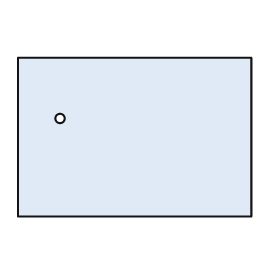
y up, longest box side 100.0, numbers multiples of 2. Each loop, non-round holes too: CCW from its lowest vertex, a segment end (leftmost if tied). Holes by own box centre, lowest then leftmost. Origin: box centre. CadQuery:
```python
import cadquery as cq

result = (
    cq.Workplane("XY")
    .moveTo(-50.0, -34.0)
    .lineTo(50.0, -34.0)
    .lineTo(50.0, 34.0)
    .lineTo(-50.0, 34.0)
    .close()
    .moveTo(-32.0, 8.0)
    .circle(2.0)
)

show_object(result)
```